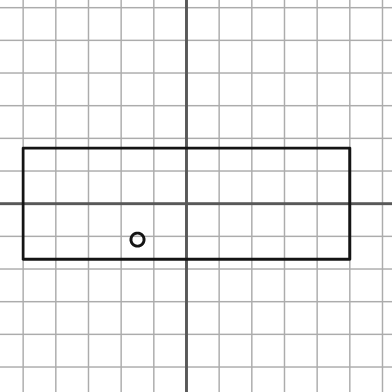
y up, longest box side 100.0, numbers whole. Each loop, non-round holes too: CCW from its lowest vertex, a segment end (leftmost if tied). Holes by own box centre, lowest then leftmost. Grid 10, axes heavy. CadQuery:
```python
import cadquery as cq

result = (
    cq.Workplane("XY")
    .moveTo(-50.0, -17.0)
    .lineTo(50.0, -17.0)
    .lineTo(50.0, 17.0)
    .lineTo(-50.0, 17.0)
    .close()
    .moveTo(-15.0, -11.0)
    .circle(2.0)
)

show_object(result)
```